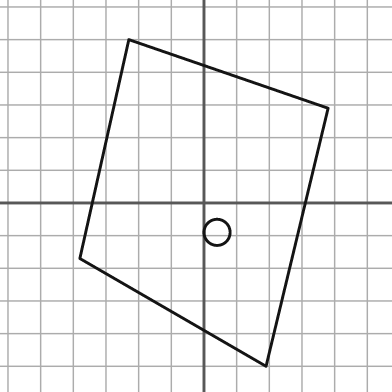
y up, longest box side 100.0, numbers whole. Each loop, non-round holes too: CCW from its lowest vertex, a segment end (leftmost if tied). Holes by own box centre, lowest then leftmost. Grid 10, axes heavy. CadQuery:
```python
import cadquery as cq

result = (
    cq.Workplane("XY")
    .moveTo(19.0, -50.0)
    .lineTo(38.0, 29.0)
    .lineTo(-23.0, 50.0)
    .lineTo(-38.0, -17.0)
    .close()
    .moveTo(4.0, -9.0)
    .circle(4.0)
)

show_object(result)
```